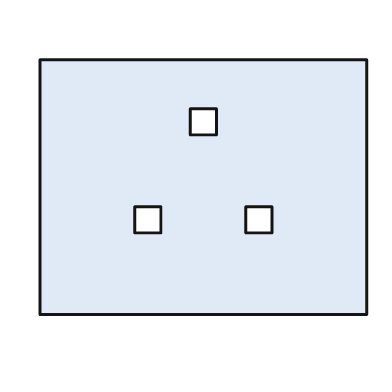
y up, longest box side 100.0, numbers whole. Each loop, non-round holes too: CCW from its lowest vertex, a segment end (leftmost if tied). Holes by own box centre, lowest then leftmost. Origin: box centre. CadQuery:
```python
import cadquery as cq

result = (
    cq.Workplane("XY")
    .moveTo(-50.0, -39.0)
    .lineTo(50.0, -39.0)
    .lineTo(50.0, 39.0)
    .lineTo(-50.0, 39.0)
    .close()
    .moveTo(-21.0, -14.0)
    .lineTo(-13.0, -14.0)
    .lineTo(-13.0, -6.0)
    .lineTo(-21.0, -6.0)
    .close()
    .moveTo(13.0, -14.0)
    .lineTo(21.0, -14.0)
    .lineTo(21.0, -6.0)
    .lineTo(13.0, -6.0)
    .close()
    .moveTo(-4.0, 16.0)
    .lineTo(4.0, 16.0)
    .lineTo(4.0, 24.0)
    .lineTo(-4.0, 24.0)
    .close()
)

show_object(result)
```